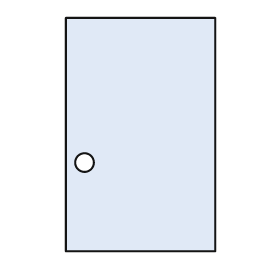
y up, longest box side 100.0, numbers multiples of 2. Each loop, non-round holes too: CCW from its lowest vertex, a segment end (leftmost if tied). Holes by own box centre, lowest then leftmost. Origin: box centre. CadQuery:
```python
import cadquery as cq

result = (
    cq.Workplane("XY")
    .moveTo(-32.0, -50.0)
    .lineTo(32.0, -50.0)
    .lineTo(32.0, 50.0)
    .lineTo(-32.0, 50.0)
    .close()
    .moveTo(-24.0, -12.0)
    .circle(4.0)
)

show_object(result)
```